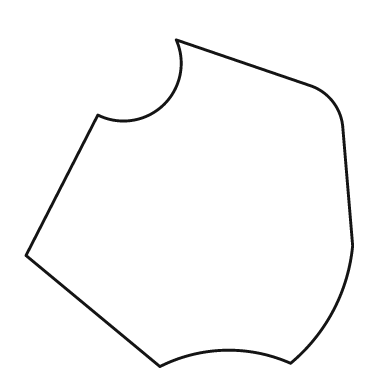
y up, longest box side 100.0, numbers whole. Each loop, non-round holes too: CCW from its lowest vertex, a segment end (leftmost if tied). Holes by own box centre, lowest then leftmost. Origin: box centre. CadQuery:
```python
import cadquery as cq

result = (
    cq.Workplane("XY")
    .moveTo(-9.0, -50.0)
    .threePointArc((11.0, -45.0), (31.0, -49.0))
    .threePointArc((44.0, -33.0), (50.0, -13.0))
    .lineTo(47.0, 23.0)
    .threePointArc((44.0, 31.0), (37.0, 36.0))
    .lineTo(-4.0, 50.0)
    .threePointArc((-8.0, 30.0), (-28.0, 27.0))
    .lineTo(-50.0, -16.0)
    .close()
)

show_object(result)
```